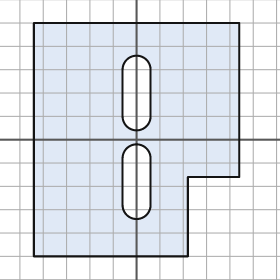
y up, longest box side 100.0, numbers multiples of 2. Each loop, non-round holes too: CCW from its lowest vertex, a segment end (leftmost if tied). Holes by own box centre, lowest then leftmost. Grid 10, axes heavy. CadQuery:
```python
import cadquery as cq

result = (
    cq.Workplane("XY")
    .moveTo(-44.0, -50.0)
    .lineTo(22.0, -50.0)
    .lineTo(22.0, -16.0)
    .lineTo(44.0, -16.0)
    .lineTo(44.0, 50.0)
    .lineTo(-44.0, 50.0)
    .close()
    .moveTo(-6.0, -28.0)
    .threePointArc((0.0, -34.0), (6.0, -28.0))
    .lineTo(6.0, -8.0)
    .threePointArc((0.0, -2.0), (-6.0, -8.0))
    .close()
    .moveTo(-6.0, 10.0)
    .threePointArc((0.0, 4.0), (6.0, 10.0))
    .lineTo(6.0, 30.0)
    .threePointArc((0.0, 36.0), (-6.0, 30.0))
    .close()
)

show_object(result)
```